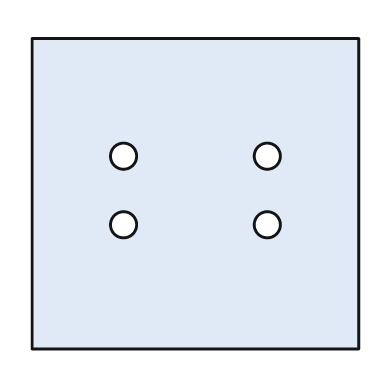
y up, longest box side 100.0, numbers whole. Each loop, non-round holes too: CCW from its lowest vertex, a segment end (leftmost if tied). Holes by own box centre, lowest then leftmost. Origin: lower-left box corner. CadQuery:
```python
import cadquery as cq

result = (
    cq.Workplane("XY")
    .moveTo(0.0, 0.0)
    .lineTo(100.0, 0.0)
    .lineTo(100.0, 95.0)
    .lineTo(0.0, 95.0)
    .close()
    .moveTo(28.0, 38.0)
    .circle(4.0)
    .moveTo(72.0, 38.0)
    .circle(4.0)
    .moveTo(28.0, 59.0)
    .circle(4.0)
    .moveTo(72.0, 59.0)
    .circle(4.0)
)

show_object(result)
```